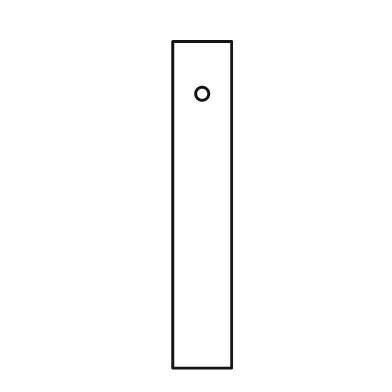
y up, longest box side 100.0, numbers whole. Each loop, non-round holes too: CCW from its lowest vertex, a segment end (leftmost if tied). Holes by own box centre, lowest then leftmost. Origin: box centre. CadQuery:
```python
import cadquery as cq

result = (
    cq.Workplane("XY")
    .moveTo(-9.0, -50.0)
    .lineTo(9.0, -50.0)
    .lineTo(9.0, 50.0)
    .lineTo(-9.0, 50.0)
    .close()
    .moveTo(0.0, 34.0)
    .circle(2.0)
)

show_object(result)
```